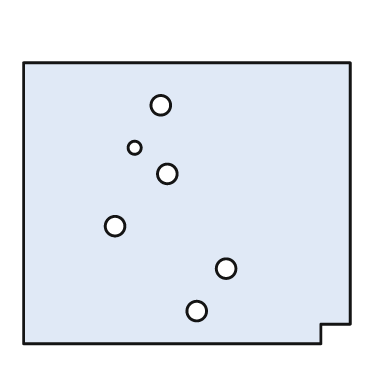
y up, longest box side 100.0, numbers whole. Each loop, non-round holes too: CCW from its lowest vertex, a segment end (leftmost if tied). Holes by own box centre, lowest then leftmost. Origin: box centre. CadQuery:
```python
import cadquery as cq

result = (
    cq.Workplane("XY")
    .moveTo(-50.0, -43.0)
    .lineTo(41.0, -43.0)
    .lineTo(41.0, -37.0)
    .lineTo(50.0, -37.0)
    .lineTo(50.0, 43.0)
    .lineTo(-50.0, 43.0)
    .close()
    .moveTo(3.0, -33.0)
    .circle(3.0)
    .moveTo(12.0, -20.0)
    .circle(3.0)
    .moveTo(-22.0, -7.0)
    .circle(3.0)
    .moveTo(-6.0, 9.0)
    .circle(3.0)
    .moveTo(-16.0, 17.0)
    .circle(2.0)
    .moveTo(-8.0, 30.0)
    .circle(3.0)
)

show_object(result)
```